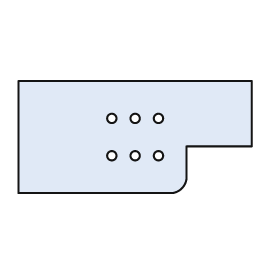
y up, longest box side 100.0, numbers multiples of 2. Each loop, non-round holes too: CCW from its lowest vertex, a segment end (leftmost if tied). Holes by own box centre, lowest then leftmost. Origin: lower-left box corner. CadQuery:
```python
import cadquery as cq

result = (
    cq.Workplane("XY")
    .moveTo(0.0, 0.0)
    .lineTo(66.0, 0.0)
    .threePointArc((70.0, 2.0), (72.0, 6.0))
    .lineTo(72.0, 20.0)
    .lineTo(100.0, 20.0)
    .lineTo(100.0, 48.0)
    .lineTo(0.0, 48.0)
    .close()
    .moveTo(40.0, 16.0)
    .circle(2.0)
    .moveTo(50.0, 16.0)
    .circle(2.0)
    .moveTo(60.0, 16.0)
    .circle(2.0)
    .moveTo(40.0, 32.0)
    .circle(2.0)
    .moveTo(50.0, 32.0)
    .circle(2.0)
    .moveTo(60.0, 32.0)
    .circle(2.0)
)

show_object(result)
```